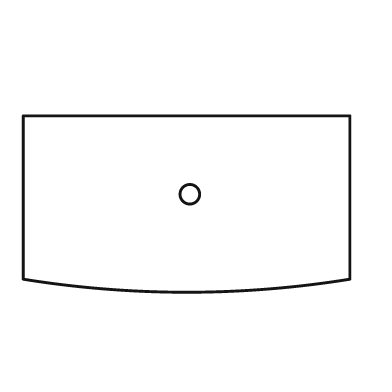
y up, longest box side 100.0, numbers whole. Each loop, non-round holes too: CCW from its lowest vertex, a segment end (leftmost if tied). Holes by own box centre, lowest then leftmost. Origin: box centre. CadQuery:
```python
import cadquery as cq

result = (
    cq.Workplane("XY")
    .moveTo(-50.0, -23.0)
    .threePointArc((0.0, -27.0), (50.0, -23.0))
    .lineTo(50.0, 27.0)
    .lineTo(-50.0, 27.0)
    .close()
    .moveTo(1.0, 3.0)
    .circle(3.0)
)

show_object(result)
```